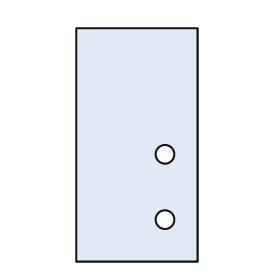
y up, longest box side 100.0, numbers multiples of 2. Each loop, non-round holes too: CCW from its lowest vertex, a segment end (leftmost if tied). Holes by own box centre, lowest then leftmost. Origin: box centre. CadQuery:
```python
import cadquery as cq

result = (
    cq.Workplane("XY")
    .moveTo(-26.0, -50.0)
    .lineTo(26.0, -50.0)
    .lineTo(26.0, 50.0)
    .lineTo(-26.0, 50.0)
    .close()
    .moveTo(12.0, -32.0)
    .circle(4.0)
    .moveTo(12.0, -4.0)
    .circle(4.0)
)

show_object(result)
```